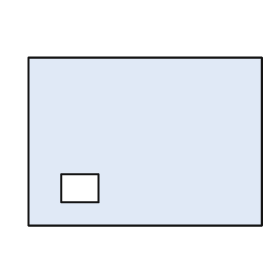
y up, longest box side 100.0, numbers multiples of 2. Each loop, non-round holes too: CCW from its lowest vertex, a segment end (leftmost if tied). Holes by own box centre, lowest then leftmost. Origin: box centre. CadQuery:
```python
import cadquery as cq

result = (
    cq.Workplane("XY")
    .moveTo(-50.0, -36.0)
    .lineTo(50.0, -36.0)
    .lineTo(50.0, 36.0)
    .lineTo(-50.0, 36.0)
    .close()
    .moveTo(-36.0, -26.0)
    .lineTo(-20.0, -26.0)
    .lineTo(-20.0, -14.0)
    .lineTo(-36.0, -14.0)
    .close()
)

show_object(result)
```